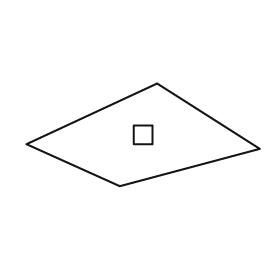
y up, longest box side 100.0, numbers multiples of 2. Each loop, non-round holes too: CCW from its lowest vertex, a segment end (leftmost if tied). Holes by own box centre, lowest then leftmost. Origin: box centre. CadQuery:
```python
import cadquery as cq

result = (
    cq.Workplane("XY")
    .moveTo(-10.0, -22.0)
    .lineTo(50.0, -6.0)
    .lineTo(6.0, 22.0)
    .lineTo(-50.0, -4.0)
    .close()
    .moveTo(-4.0, -4.0)
    .lineTo(4.0, -4.0)
    .lineTo(4.0, 4.0)
    .lineTo(-4.0, 4.0)
    .close()
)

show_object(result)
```